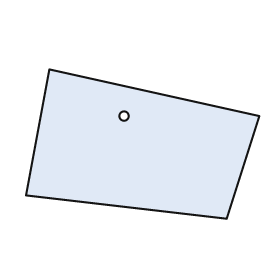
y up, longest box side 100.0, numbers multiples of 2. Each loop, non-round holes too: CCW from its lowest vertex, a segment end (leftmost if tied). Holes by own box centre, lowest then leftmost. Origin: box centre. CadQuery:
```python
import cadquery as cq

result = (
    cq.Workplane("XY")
    .moveTo(36.0, -32.0)
    .lineTo(50.0, 12.0)
    .lineTo(-40.0, 32.0)
    .lineTo(-50.0, -22.0)
    .close()
    .moveTo(-8.0, 12.0)
    .circle(2.0)
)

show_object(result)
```